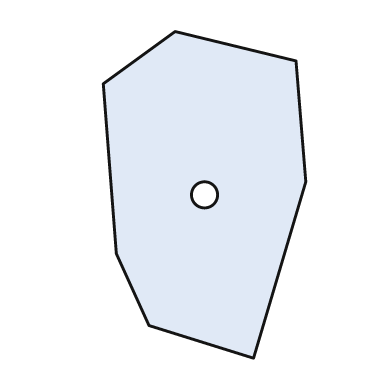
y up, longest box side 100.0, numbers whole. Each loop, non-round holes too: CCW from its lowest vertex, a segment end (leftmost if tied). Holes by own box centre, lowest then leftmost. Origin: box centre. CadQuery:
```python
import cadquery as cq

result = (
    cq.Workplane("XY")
    .moveTo(15.0, -50.0)
    .lineTo(31.0, 4.0)
    .lineTo(28.0, 41.0)
    .lineTo(-9.0, 50.0)
    .lineTo(-31.0, 34.0)
    .lineTo(-27.0, -18.0)
    .lineTo(-17.0, -40.0)
    .close()
    .moveTo(0.0, 0.0)
    .circle(4.0)
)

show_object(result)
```